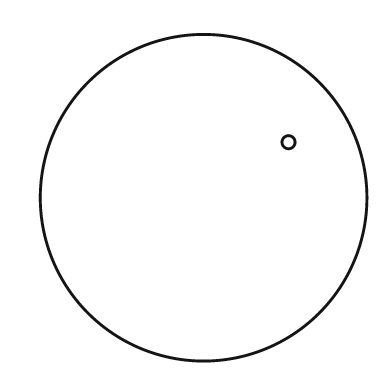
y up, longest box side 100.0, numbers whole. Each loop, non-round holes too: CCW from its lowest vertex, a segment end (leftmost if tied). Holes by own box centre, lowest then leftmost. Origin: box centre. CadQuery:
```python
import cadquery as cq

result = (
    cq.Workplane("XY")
    .moveTo(0.0, 0.0)
    .circle(50.0)
    .moveTo(26.0, 17.0)
    .circle(2.0)
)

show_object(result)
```